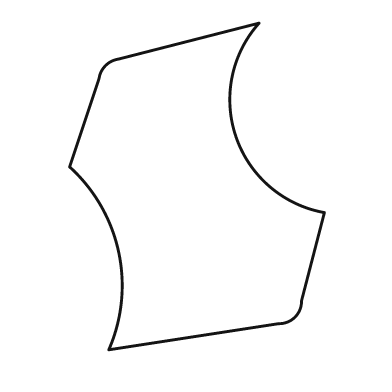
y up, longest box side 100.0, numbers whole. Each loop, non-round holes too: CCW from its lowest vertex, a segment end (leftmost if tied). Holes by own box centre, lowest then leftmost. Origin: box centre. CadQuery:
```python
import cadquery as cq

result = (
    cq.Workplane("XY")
    .moveTo(-27.0, -50.0)
    .lineTo(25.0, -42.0)
    .threePointArc((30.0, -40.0), (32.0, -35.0))
    .lineTo(39.0, -8.0)
    .threePointArc((12.0, 15.0), (19.0, 50.0))
    .lineTo(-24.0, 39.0)
    .threePointArc((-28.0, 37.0), (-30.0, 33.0))
    .lineTo(-39.0, 6.0)
    .threePointArc((-24.0, -20.0), (-27.0, -50.0))
    .close()
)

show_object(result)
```